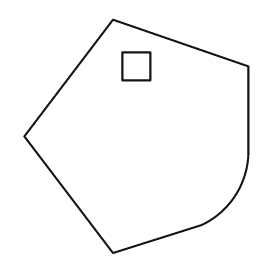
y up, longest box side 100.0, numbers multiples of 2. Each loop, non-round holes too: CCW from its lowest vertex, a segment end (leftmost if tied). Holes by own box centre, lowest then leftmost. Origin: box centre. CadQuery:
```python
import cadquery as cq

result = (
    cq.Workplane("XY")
    .moveTo(-10.0, -50.0)
    .lineTo(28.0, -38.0)
    .threePointArc((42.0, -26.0), (48.0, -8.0))
    .lineTo(48.0, 30.0)
    .lineTo(-10.0, 50.0)
    .lineTo(-48.0, 0.0)
    .close()
    .moveTo(-6.0, 24.0)
    .lineTo(6.0, 24.0)
    .lineTo(6.0, 36.0)
    .lineTo(-6.0, 36.0)
    .close()
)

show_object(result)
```